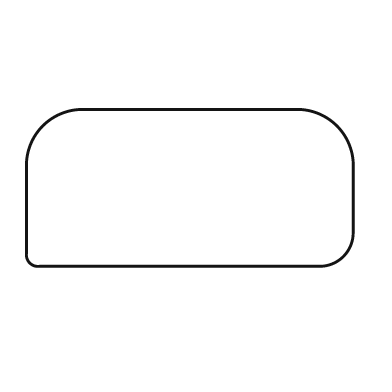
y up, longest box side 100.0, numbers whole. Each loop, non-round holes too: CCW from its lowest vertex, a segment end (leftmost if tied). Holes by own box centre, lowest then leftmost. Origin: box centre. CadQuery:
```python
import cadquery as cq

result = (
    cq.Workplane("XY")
    .moveTo(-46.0, -24.0)
    .lineTo(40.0, -24.0)
    .threePointArc((47.0, -21.0), (50.0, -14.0))
    .lineTo(50.0, 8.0)
    .threePointArc((45.0, 19.0), (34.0, 24.0))
    .lineTo(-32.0, 24.0)
    .threePointArc((-45.0, 19.0), (-50.0, 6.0))
    .lineTo(-50.0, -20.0)
    .threePointArc((-49.0, -23.0), (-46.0, -24.0))
    .close()
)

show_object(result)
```